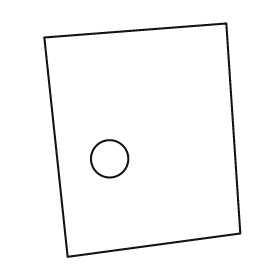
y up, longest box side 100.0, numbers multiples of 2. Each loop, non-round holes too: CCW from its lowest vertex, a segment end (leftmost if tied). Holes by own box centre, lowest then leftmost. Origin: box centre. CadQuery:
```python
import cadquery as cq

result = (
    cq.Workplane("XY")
    .moveTo(-32.0, -50.0)
    .lineTo(42.0, -40.0)
    .lineTo(36.0, 50.0)
    .lineTo(-42.0, 44.0)
    .close()
    .moveTo(-14.0, -8.0)
    .circle(8.0)
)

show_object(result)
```